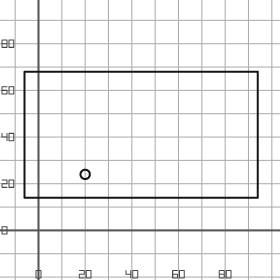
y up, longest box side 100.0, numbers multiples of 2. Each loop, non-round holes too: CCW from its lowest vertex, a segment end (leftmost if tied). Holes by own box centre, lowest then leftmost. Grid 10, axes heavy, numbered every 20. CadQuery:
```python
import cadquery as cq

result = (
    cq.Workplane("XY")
    .moveTo(-6.0, 14.0)
    .lineTo(94.0, 14.0)
    .lineTo(94.0, 68.0)
    .lineTo(-6.0, 68.0)
    .close()
    .moveTo(20.0, 24.0)
    .circle(2.0)
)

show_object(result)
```